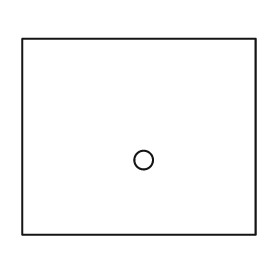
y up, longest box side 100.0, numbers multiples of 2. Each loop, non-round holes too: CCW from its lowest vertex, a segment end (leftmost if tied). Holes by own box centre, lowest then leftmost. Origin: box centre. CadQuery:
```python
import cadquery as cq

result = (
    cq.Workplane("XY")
    .moveTo(-50.0, -42.0)
    .lineTo(50.0, -42.0)
    .lineTo(50.0, 42.0)
    .lineTo(-50.0, 42.0)
    .close()
    .moveTo(2.0, -10.0)
    .circle(4.0)
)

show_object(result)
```